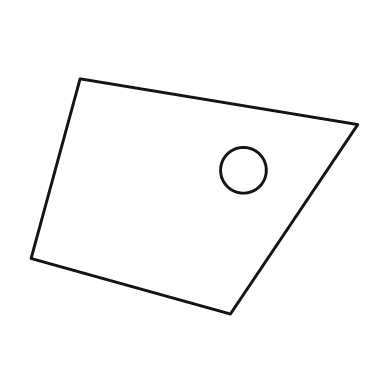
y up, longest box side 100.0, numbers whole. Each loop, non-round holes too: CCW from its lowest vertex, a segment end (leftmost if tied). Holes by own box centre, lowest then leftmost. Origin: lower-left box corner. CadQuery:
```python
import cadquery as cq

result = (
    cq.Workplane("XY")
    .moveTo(61.0, 0.0)
    .lineTo(100.0, 58.0)
    .lineTo(15.0, 72.0)
    .lineTo(0.0, 17.0)
    .close()
    .moveTo(65.0, 44.0)
    .circle(7.0)
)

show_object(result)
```